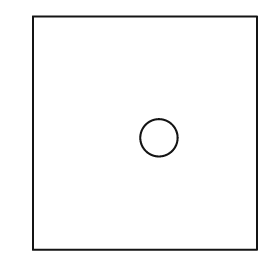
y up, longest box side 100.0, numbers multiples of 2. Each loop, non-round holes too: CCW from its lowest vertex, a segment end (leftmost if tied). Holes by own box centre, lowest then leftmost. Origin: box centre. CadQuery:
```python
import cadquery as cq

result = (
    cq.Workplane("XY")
    .moveTo(-48.0, -50.0)
    .lineTo(48.0, -50.0)
    .lineTo(48.0, 50.0)
    .lineTo(-48.0, 50.0)
    .close()
    .moveTo(6.0, -2.0)
    .circle(8.0)
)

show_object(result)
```